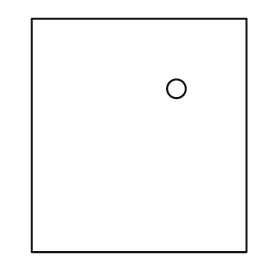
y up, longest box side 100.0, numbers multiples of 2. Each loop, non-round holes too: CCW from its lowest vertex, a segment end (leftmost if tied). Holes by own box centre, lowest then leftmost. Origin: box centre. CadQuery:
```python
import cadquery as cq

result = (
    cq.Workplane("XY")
    .moveTo(-46.0, -50.0)
    .lineTo(46.0, -50.0)
    .lineTo(46.0, 50.0)
    .lineTo(-46.0, 50.0)
    .close()
    .moveTo(16.0, 20.0)
    .circle(4.0)
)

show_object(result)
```